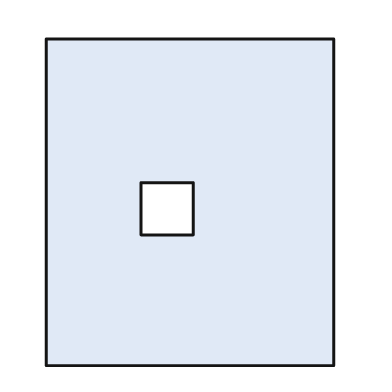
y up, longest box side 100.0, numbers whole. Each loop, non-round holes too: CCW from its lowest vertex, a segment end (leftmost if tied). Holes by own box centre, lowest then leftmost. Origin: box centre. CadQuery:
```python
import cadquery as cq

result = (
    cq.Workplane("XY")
    .moveTo(-44.0, -50.0)
    .lineTo(44.0, -50.0)
    .lineTo(44.0, 50.0)
    .lineTo(-44.0, 50.0)
    .close()
    .moveTo(-15.0, -10.0)
    .lineTo(1.0, -10.0)
    .lineTo(1.0, 6.0)
    .lineTo(-15.0, 6.0)
    .close()
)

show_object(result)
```